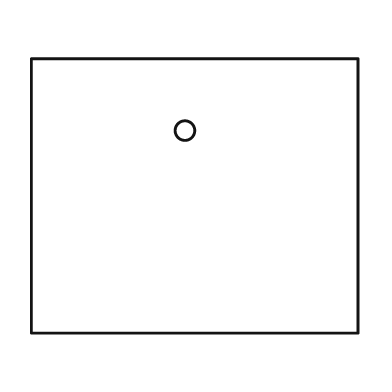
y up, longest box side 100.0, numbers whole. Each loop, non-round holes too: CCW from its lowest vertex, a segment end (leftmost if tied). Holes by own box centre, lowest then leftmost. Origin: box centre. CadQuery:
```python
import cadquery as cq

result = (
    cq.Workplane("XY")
    .moveTo(-50.0, -42.0)
    .lineTo(50.0, -42.0)
    .lineTo(50.0, 42.0)
    .lineTo(-50.0, 42.0)
    .close()
    .moveTo(-3.0, 20.0)
    .circle(3.0)
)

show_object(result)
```